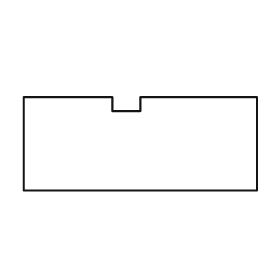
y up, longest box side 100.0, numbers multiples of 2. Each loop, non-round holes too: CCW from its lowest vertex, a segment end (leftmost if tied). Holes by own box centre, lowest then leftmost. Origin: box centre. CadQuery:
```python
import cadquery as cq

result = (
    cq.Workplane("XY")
    .moveTo(-50.0, -20.0)
    .lineTo(50.0, -20.0)
    .lineTo(50.0, 20.0)
    .lineTo(0.0, 20.0)
    .lineTo(0.0, 14.0)
    .lineTo(-12.0, 14.0)
    .lineTo(-12.0, 20.0)
    .lineTo(-50.0, 20.0)
    .close()
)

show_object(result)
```